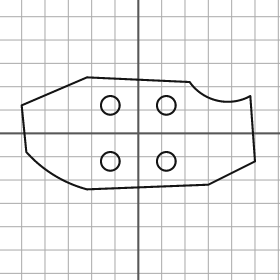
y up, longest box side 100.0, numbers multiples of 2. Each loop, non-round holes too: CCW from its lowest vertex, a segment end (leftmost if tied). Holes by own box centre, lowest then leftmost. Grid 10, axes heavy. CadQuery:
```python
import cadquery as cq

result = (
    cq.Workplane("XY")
    .moveTo(-22.0, -24.0)
    .lineTo(30.0, -22.0)
    .lineTo(50.0, -12.0)
    .lineTo(48.0, 16.0)
    .threePointArc((34.0, 14.0), (22.0, 22.0))
    .lineTo(-22.0, 24.0)
    .lineTo(-50.0, 12.0)
    .lineTo(-48.0, -8.0)
    .threePointArc((-36.0, -18.0), (-22.0, -24.0))
    .close()
    .moveTo(-12.0, -12.0)
    .circle(4.0)
    .moveTo(12.0, -12.0)
    .circle(4.0)
    .moveTo(-12.0, 12.0)
    .circle(4.0)
    .moveTo(12.0, 12.0)
    .circle(4.0)
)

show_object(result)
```